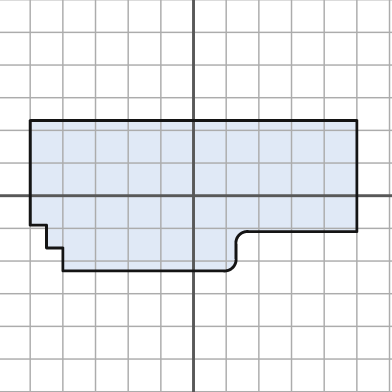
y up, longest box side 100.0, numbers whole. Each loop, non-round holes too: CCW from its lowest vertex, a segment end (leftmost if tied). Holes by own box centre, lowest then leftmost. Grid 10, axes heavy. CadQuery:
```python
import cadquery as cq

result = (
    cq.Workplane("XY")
    .moveTo(-40.0, -23.0)
    .lineTo(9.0, -23.0)
    .threePointArc((12.0, -22.0), (13.0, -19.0))
    .lineTo(13.0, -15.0)
    .threePointArc((14.0, -12.0), (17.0, -11.0))
    .lineTo(50.0, -11.0)
    .lineTo(50.0, 23.0)
    .lineTo(-50.0, 23.0)
    .lineTo(-50.0, -9.0)
    .lineTo(-45.0, -9.0)
    .lineTo(-45.0, -16.0)
    .lineTo(-40.0, -16.0)
    .close()
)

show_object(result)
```